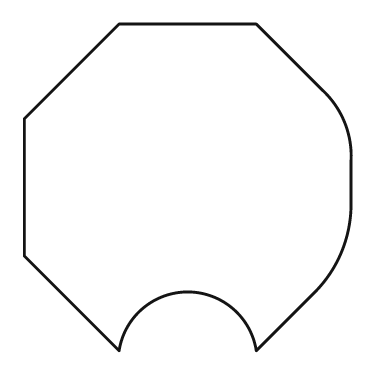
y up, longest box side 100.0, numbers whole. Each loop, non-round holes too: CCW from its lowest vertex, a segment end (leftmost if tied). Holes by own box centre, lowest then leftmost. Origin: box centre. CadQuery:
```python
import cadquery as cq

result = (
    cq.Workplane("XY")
    .moveTo(-21.0, -50.0)
    .threePointArc((0.0, -32.0), (21.0, -50.0))
    .lineTo(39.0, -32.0)
    .threePointArc((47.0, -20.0), (50.0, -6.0))
    .lineTo(50.0, 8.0)
    .threePointArc((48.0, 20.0), (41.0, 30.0))
    .lineTo(21.0, 50.0)
    .lineTo(-21.0, 50.0)
    .lineTo(-50.0, 21.0)
    .lineTo(-50.0, -21.0)
    .close()
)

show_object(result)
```